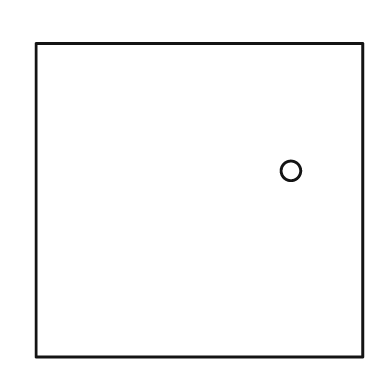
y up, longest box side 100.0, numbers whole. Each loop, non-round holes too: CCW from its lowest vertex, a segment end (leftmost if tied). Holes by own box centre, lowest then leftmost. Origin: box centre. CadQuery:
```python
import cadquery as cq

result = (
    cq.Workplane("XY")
    .moveTo(-50.0, -48.0)
    .lineTo(50.0, -48.0)
    .lineTo(50.0, 48.0)
    .lineTo(-50.0, 48.0)
    .close()
    .moveTo(28.0, 9.0)
    .circle(3.0)
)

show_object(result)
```